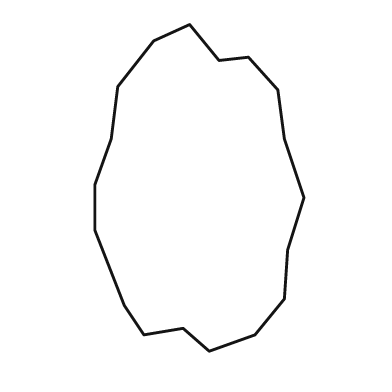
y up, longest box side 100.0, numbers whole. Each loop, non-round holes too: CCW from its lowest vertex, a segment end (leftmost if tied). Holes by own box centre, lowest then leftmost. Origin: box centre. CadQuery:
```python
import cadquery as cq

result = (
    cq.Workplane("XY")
    .moveTo(3.0, -50.0)
    .lineTo(17.0, -45.0)
    .lineTo(26.0, -34.0)
    .lineTo(27.0, -19.0)
    .lineTo(32.0, -3.0)
    .lineTo(26.0, 15.0)
    .lineTo(24.0, 30.0)
    .lineTo(15.0, 40.0)
    .lineTo(6.0, 39.0)
    .lineTo(-3.0, 50.0)
    .lineTo(-14.0, 45.0)
    .lineTo(-25.0, 31.0)
    .lineTo(-27.0, 15.0)
    .lineTo(-32.0, 1.0)
    .lineTo(-32.0, -13.0)
    .lineTo(-23.0, -36.0)
    .lineTo(-17.0, -45.0)
    .lineTo(-5.0, -43.0)
    .close()
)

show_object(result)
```